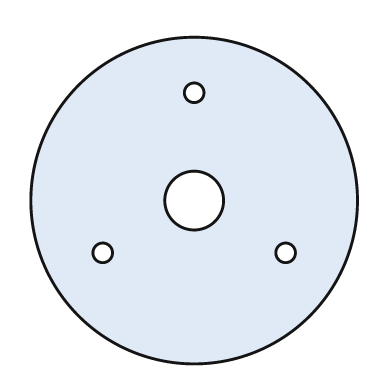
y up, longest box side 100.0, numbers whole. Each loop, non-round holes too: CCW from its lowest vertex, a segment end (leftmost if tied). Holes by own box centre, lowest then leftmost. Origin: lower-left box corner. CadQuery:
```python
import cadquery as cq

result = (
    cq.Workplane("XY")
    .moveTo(50.0, 50.0)
    .circle(50.0)
    .moveTo(22.0, 34.0)
    .circle(3.0)
    .moveTo(78.0, 34.0)
    .circle(3.0)
    .moveTo(50.0, 50.0)
    .circle(9.0)
    .moveTo(50.0, 83.0)
    .circle(3.0)
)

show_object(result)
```